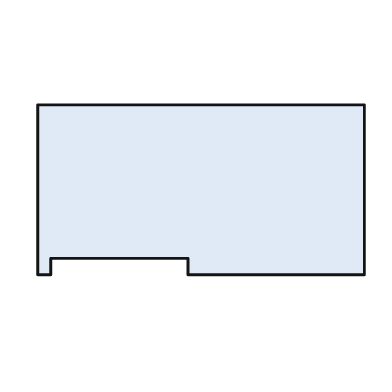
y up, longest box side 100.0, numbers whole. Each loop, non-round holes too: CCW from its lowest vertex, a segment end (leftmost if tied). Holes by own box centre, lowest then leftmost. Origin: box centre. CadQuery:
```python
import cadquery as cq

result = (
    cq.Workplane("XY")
    .moveTo(-50.0, -26.0)
    .lineTo(-46.0, -26.0)
    .lineTo(-46.0, -21.0)
    .lineTo(-4.0, -21.0)
    .lineTo(-4.0, -26.0)
    .lineTo(50.0, -26.0)
    .lineTo(50.0, 26.0)
    .lineTo(-50.0, 26.0)
    .close()
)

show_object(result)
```